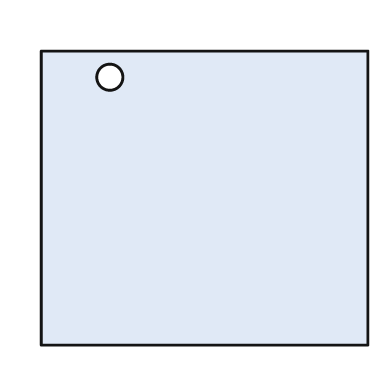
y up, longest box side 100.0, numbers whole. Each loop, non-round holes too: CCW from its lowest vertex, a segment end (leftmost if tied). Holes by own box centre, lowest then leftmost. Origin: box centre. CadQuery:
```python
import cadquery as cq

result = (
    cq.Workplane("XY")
    .moveTo(-50.0, -45.0)
    .lineTo(50.0, -45.0)
    .lineTo(50.0, 45.0)
    .lineTo(-50.0, 45.0)
    .close()
    .moveTo(-29.0, 37.0)
    .circle(4.0)
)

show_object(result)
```